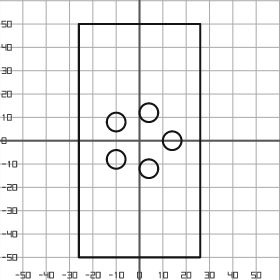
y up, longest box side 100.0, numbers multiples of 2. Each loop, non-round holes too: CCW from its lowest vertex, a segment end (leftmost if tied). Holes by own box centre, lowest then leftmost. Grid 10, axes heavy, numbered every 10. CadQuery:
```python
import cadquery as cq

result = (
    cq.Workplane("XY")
    .moveTo(-26.0, -50.0)
    .lineTo(26.0, -50.0)
    .lineTo(26.0, 50.0)
    .lineTo(-26.0, 50.0)
    .close()
    .moveTo(4.0, -12.0)
    .circle(4.0)
    .moveTo(-10.0, -8.0)
    .circle(4.0)
    .moveTo(14.0, 0.0)
    .circle(4.0)
    .moveTo(-10.0, 8.0)
    .circle(4.0)
    .moveTo(4.0, 12.0)
    .circle(4.0)
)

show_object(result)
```